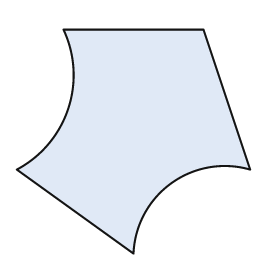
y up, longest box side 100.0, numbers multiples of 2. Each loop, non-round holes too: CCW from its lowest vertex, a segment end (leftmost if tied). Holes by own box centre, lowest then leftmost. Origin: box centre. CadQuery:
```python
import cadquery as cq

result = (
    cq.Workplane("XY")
    .moveTo(0.0, -48.0)
    .threePointArc((16.0, -18.0), (50.0, -12.0))
    .lineTo(30.0, 48.0)
    .lineTo(-30.0, 48.0)
    .threePointArc((-28.0, 14.0), (-50.0, -12.0))
    .close()
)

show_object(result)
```